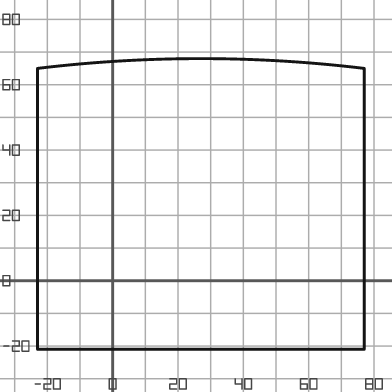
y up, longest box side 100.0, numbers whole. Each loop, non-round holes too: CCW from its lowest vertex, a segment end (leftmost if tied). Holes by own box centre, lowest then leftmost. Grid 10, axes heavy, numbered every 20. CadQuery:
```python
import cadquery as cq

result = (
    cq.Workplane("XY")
    .moveTo(-23.0, -21.0)
    .lineTo(77.0, -21.0)
    .lineTo(77.0, 65.0)
    .threePointArc((27.0, 68.0), (-23.0, 65.0))
    .close()
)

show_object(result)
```